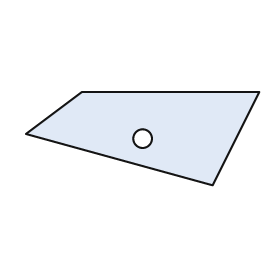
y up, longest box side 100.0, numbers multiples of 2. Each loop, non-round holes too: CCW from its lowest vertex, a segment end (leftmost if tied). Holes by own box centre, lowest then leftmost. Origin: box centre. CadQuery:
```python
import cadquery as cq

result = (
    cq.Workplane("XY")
    .moveTo(30.0, -20.0)
    .lineTo(50.0, 20.0)
    .lineTo(-26.0, 20.0)
    .lineTo(-50.0, 2.0)
    .close()
    .moveTo(0.0, 0.0)
    .circle(4.0)
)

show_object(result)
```